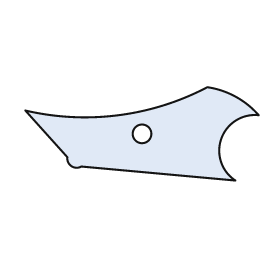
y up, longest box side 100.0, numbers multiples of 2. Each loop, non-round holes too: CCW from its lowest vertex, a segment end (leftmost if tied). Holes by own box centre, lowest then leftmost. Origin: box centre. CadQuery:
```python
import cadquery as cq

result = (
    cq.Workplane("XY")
    .moveTo(40.0, -20.0)
    .threePointArc((34.0, -2.0), (50.0, 8.0))
    .threePointArc((40.0, 16.0), (28.0, 20.0))
    .threePointArc((-10.0, 8.0), (-50.0, 10.0))
    .lineTo(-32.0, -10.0)
    .threePointArc((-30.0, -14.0), (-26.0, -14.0))
    .close()
    .moveTo(0.0, 0.0)
    .circle(4.0)
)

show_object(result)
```